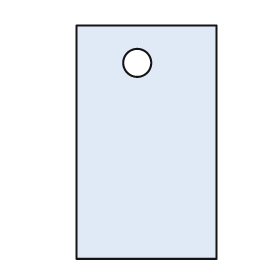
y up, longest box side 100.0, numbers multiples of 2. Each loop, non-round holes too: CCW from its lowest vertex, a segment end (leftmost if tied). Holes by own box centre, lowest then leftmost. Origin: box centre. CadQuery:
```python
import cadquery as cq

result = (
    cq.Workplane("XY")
    .moveTo(-30.0, -50.0)
    .lineTo(30.0, -50.0)
    .lineTo(30.0, 50.0)
    .lineTo(-30.0, 50.0)
    .close()
    .moveTo(-4.0, 34.0)
    .circle(6.0)
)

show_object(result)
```